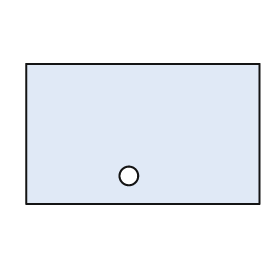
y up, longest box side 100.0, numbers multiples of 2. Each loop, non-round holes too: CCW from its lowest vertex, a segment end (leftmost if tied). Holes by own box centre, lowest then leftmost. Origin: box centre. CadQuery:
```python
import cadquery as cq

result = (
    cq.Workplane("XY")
    .moveTo(-50.0, -30.0)
    .lineTo(50.0, -30.0)
    .lineTo(50.0, 30.0)
    .lineTo(-50.0, 30.0)
    .close()
    .moveTo(-6.0, -18.0)
    .circle(4.0)
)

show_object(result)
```